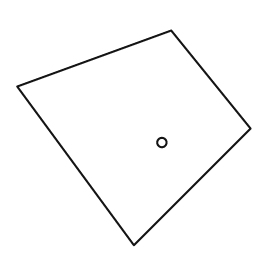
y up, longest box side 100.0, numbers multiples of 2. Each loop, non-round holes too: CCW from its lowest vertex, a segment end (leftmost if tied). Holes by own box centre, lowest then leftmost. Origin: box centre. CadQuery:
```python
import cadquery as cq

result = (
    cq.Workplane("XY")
    .moveTo(0.0, -46.0)
    .lineTo(50.0, 4.0)
    .lineTo(16.0, 46.0)
    .lineTo(-50.0, 22.0)
    .close()
    .moveTo(12.0, -2.0)
    .circle(2.0)
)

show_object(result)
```